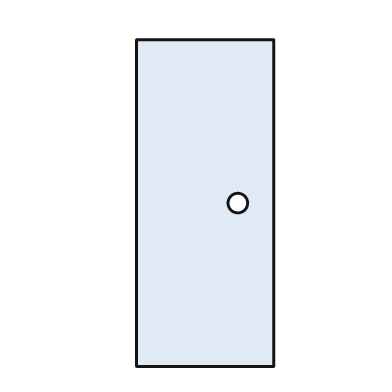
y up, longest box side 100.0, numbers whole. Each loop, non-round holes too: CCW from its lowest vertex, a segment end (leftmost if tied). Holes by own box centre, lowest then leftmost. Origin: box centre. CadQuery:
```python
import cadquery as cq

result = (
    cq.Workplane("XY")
    .moveTo(-21.0, -50.0)
    .lineTo(21.0, -50.0)
    .lineTo(21.0, 50.0)
    .lineTo(-21.0, 50.0)
    .close()
    .moveTo(10.0, 0.0)
    .circle(3.0)
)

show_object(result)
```